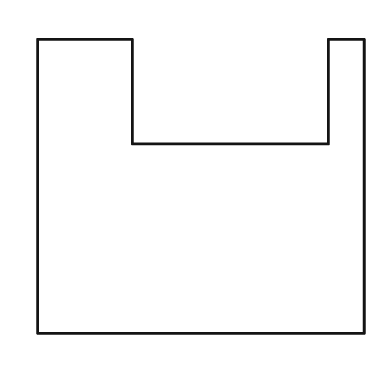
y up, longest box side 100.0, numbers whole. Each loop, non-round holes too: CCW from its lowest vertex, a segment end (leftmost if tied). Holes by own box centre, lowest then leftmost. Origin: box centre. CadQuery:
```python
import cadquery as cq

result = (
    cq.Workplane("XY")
    .moveTo(-50.0, -45.0)
    .lineTo(50.0, -45.0)
    .lineTo(50.0, 45.0)
    .lineTo(39.0, 45.0)
    .lineTo(39.0, 13.0)
    .lineTo(-21.0, 13.0)
    .lineTo(-21.0, 45.0)
    .lineTo(-50.0, 45.0)
    .close()
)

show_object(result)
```